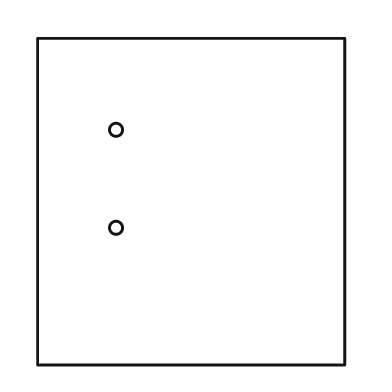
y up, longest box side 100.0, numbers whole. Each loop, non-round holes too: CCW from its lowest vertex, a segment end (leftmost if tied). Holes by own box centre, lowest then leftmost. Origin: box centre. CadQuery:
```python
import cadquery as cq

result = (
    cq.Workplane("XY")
    .moveTo(-47.0, -50.0)
    .lineTo(47.0, -50.0)
    .lineTo(47.0, 50.0)
    .lineTo(-47.0, 50.0)
    .close()
    .moveTo(-23.0, -8.0)
    .circle(2.0)
    .moveTo(-23.0, 22.0)
    .circle(2.0)
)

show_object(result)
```